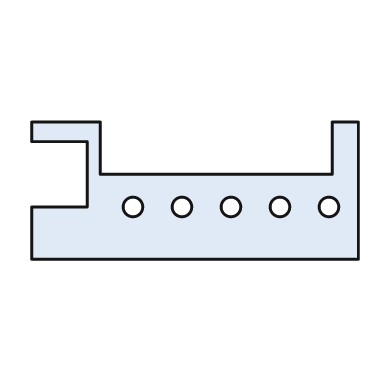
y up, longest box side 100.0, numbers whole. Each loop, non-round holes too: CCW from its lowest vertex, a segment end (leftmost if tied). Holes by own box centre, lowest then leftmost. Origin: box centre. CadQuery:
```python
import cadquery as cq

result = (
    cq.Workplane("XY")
    .moveTo(-50.0, -21.0)
    .lineTo(50.0, -21.0)
    .lineTo(50.0, 21.0)
    .lineTo(42.0, 21.0)
    .lineTo(42.0, 5.0)
    .lineTo(-29.0, 5.0)
    .lineTo(-29.0, 21.0)
    .lineTo(-50.0, 21.0)
    .lineTo(-50.0, 15.0)
    .lineTo(-33.0, 15.0)
    .lineTo(-33.0, -5.0)
    .lineTo(-50.0, -5.0)
    .close()
    .moveTo(-19.0, -5.0)
    .circle(3.0)
    .moveTo(-4.0, -5.0)
    .circle(3.0)
    .moveTo(11.0, -5.0)
    .circle(3.0)
    .moveTo(26.0, -5.0)
    .circle(3.0)
    .moveTo(41.0, -5.0)
    .circle(3.0)
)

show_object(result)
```